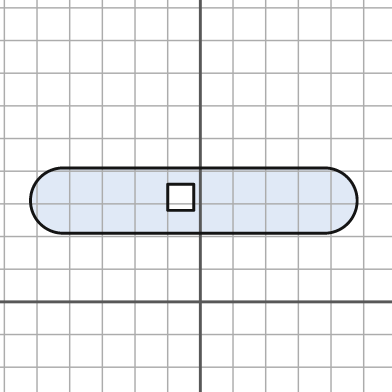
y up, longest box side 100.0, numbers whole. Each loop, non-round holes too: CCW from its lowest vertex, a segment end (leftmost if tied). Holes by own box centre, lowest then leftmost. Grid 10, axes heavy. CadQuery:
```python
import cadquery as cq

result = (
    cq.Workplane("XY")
    .moveTo(-42.0, 21.0)
    .lineTo(38.0, 21.0)
    .threePointArc((48.0, 31.0), (38.0, 41.0))
    .lineTo(-42.0, 41.0)
    .threePointArc((-52.0, 31.0), (-42.0, 21.0))
    .close()
    .moveTo(-10.0, 28.0)
    .lineTo(-2.0, 28.0)
    .lineTo(-2.0, 36.0)
    .lineTo(-10.0, 36.0)
    .close()
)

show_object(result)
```